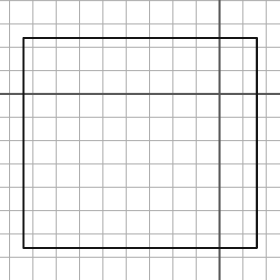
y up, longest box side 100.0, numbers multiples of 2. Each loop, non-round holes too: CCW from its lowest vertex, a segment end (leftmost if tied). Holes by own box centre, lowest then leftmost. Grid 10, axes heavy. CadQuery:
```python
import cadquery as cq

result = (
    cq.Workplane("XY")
    .moveTo(-84.0, -66.0)
    .lineTo(16.0, -66.0)
    .lineTo(16.0, 24.0)
    .lineTo(-84.0, 24.0)
    .close()
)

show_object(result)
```